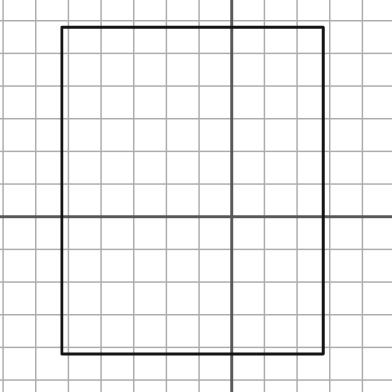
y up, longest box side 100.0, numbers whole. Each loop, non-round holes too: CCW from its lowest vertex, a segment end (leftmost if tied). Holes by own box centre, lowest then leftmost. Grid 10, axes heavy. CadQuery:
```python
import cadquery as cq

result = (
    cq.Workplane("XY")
    .moveTo(-52.0, -42.0)
    .lineTo(28.0, -42.0)
    .lineTo(28.0, 58.0)
    .lineTo(-52.0, 58.0)
    .close()
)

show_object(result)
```